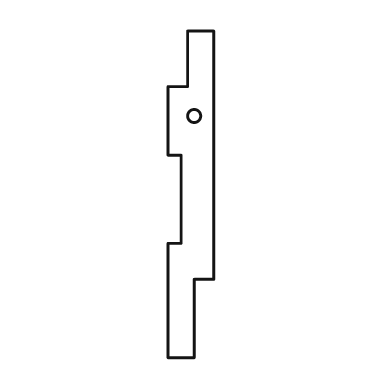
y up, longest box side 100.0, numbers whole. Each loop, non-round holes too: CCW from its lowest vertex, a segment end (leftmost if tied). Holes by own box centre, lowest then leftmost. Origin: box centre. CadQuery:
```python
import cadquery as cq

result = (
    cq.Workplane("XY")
    .moveTo(-7.0, -50.0)
    .lineTo(1.0, -50.0)
    .lineTo(1.0, -26.0)
    .lineTo(7.0, -26.0)
    .lineTo(7.0, 50.0)
    .lineTo(-1.0, 50.0)
    .lineTo(-1.0, 33.0)
    .lineTo(-7.0, 33.0)
    .lineTo(-7.0, 12.0)
    .lineTo(-3.0, 12.0)
    .lineTo(-3.0, -15.0)
    .lineTo(-7.0, -15.0)
    .close()
    .moveTo(1.0, 24.0)
    .circle(2.0)
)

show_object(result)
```